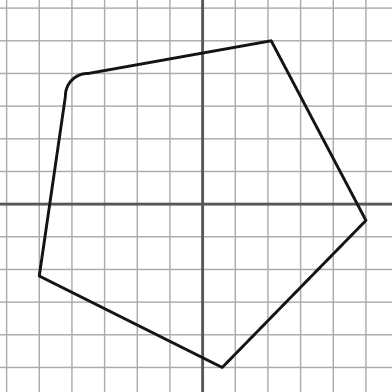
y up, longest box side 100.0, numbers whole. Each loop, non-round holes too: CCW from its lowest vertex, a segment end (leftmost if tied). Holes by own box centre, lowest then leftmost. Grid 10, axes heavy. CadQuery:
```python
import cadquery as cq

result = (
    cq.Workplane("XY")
    .moveTo(6.0, -50.0)
    .lineTo(50.0, -5.0)
    .lineTo(21.0, 50.0)
    .lineTo(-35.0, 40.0)
    .threePointArc((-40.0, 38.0), (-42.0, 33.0))
    .lineTo(-50.0, -22.0)
    .close()
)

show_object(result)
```